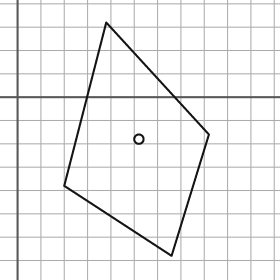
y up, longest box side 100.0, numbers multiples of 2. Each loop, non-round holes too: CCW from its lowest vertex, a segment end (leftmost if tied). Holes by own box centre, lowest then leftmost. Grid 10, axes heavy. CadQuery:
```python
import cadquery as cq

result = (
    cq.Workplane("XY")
    .moveTo(66.0, -68.0)
    .lineTo(82.0, -16.0)
    .lineTo(38.0, 32.0)
    .lineTo(20.0, -38.0)
    .close()
    .moveTo(52.0, -18.0)
    .circle(2.0)
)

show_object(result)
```